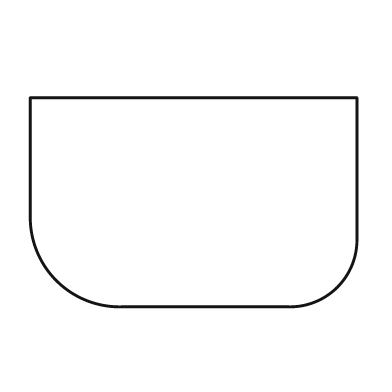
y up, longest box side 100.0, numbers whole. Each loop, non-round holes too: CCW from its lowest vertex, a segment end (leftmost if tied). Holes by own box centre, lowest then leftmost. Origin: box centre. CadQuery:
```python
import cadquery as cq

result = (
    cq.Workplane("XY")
    .moveTo(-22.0, -32.0)
    .lineTo(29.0, -32.0)
    .threePointArc((44.0, -26.0), (50.0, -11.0))
    .lineTo(50.0, 32.0)
    .lineTo(-50.0, 32.0)
    .lineTo(-50.0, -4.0)
    .threePointArc((-42.0, -24.0), (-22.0, -32.0))
    .close()
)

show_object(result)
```